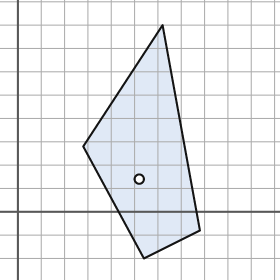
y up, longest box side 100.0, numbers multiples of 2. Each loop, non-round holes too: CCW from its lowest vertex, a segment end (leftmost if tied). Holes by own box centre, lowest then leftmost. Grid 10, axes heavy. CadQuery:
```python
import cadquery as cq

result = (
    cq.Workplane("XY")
    .moveTo(54.0, -20.0)
    .lineTo(78.0, -8.0)
    .lineTo(62.0, 80.0)
    .lineTo(28.0, 28.0)
    .close()
    .moveTo(52.0, 14.0)
    .circle(2.0)
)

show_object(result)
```